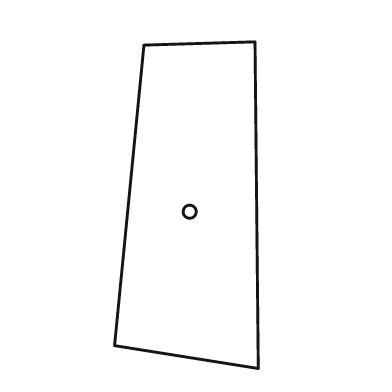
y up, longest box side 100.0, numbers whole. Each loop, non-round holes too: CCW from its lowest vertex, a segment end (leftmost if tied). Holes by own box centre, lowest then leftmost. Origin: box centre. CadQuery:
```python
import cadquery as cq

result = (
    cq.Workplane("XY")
    .moveTo(22.0, -50.0)
    .lineTo(21.0, 50.0)
    .lineTo(-13.0, 49.0)
    .lineTo(-22.0, -43.0)
    .close()
    .moveTo(1.0, -2.0)
    .circle(2.0)
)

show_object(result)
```